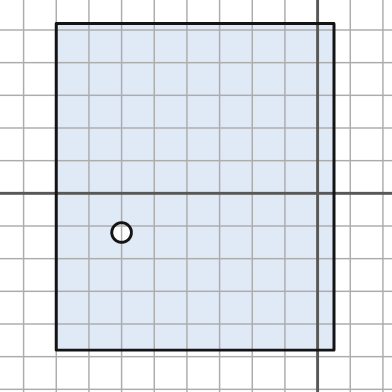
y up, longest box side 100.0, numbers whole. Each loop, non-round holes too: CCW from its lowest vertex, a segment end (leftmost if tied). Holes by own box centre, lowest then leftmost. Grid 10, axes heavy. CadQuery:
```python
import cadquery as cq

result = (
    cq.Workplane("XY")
    .moveTo(-80.0, -48.0)
    .lineTo(5.0, -48.0)
    .lineTo(5.0, 52.0)
    .lineTo(-80.0, 52.0)
    .close()
    .moveTo(-60.0, -12.0)
    .circle(3.0)
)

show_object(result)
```